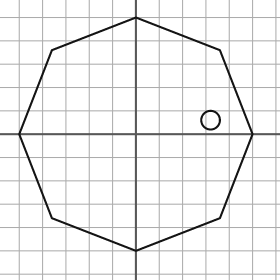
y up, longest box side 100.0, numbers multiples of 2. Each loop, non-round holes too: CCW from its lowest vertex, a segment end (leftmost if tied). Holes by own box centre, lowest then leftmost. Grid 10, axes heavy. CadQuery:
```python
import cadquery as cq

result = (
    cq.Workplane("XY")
    .moveTo(0.0, -50.0)
    .lineTo(36.0, -36.0)
    .lineTo(50.0, 0.0)
    .lineTo(36.0, 36.0)
    .lineTo(0.0, 50.0)
    .lineTo(-36.0, 36.0)
    .lineTo(-50.0, 0.0)
    .lineTo(-36.0, -36.0)
    .close()
    .moveTo(32.0, 6.0)
    .circle(4.0)
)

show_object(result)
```